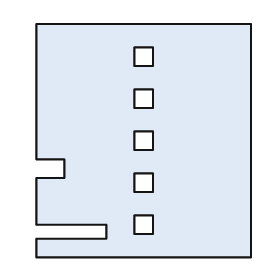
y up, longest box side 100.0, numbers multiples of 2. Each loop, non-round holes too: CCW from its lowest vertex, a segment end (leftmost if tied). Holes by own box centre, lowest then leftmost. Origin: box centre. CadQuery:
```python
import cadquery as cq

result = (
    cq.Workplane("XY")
    .moveTo(-46.0, -50.0)
    .lineTo(46.0, -50.0)
    .lineTo(46.0, 50.0)
    .lineTo(-46.0, 50.0)
    .lineTo(-46.0, -8.0)
    .lineTo(-34.0, -8.0)
    .lineTo(-34.0, -16.0)
    .lineTo(-46.0, -16.0)
    .lineTo(-46.0, -36.0)
    .lineTo(-16.0, -36.0)
    .lineTo(-16.0, -42.0)
    .lineTo(-46.0, -42.0)
    .close()
    .moveTo(-4.0, -40.0)
    .lineTo(4.0, -40.0)
    .lineTo(4.0, -32.0)
    .lineTo(-4.0, -32.0)
    .close()
    .moveTo(-4.0, -22.0)
    .lineTo(4.0, -22.0)
    .lineTo(4.0, -14.0)
    .lineTo(-4.0, -14.0)
    .close()
    .moveTo(-4.0, -4.0)
    .lineTo(4.0, -4.0)
    .lineTo(4.0, 4.0)
    .lineTo(-4.0, 4.0)
    .close()
    .moveTo(-4.0, 14.0)
    .lineTo(4.0, 14.0)
    .lineTo(4.0, 22.0)
    .lineTo(-4.0, 22.0)
    .close()
    .moveTo(-4.0, 32.0)
    .lineTo(4.0, 32.0)
    .lineTo(4.0, 40.0)
    .lineTo(-4.0, 40.0)
    .close()
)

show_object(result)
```